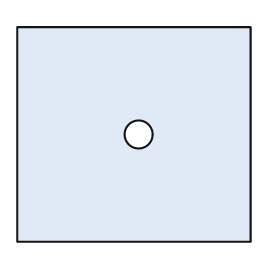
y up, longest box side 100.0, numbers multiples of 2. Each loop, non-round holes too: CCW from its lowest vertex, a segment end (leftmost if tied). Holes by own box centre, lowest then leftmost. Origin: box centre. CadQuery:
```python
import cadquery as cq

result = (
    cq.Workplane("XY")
    .moveTo(-50.0, -46.0)
    .lineTo(50.0, -46.0)
    .lineTo(50.0, 46.0)
    .lineTo(-50.0, 46.0)
    .close()
    .moveTo(2.0, 0.0)
    .circle(6.0)
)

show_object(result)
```